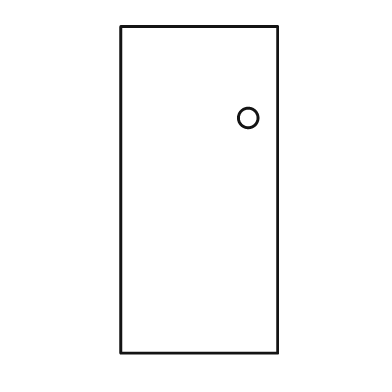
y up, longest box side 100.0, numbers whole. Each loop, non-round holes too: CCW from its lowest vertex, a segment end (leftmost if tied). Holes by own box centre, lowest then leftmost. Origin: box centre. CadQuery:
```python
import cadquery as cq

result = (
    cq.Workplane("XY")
    .moveTo(-24.0, -50.0)
    .lineTo(24.0, -50.0)
    .lineTo(24.0, 50.0)
    .lineTo(-24.0, 50.0)
    .close()
    .moveTo(15.0, 22.0)
    .circle(3.0)
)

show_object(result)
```